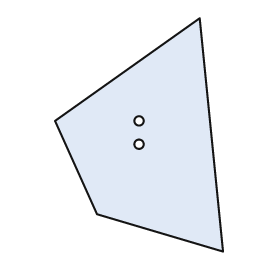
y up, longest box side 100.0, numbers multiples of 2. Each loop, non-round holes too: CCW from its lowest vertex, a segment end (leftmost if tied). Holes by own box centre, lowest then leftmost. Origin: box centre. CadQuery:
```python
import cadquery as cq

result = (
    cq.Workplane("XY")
    .moveTo(36.0, -50.0)
    .lineTo(26.0, 50.0)
    .lineTo(-36.0, 6.0)
    .lineTo(-18.0, -34.0)
    .close()
    .moveTo(0.0, -4.0)
    .circle(2.0)
    .moveTo(0.0, 6.0)
    .circle(2.0)
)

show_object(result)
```